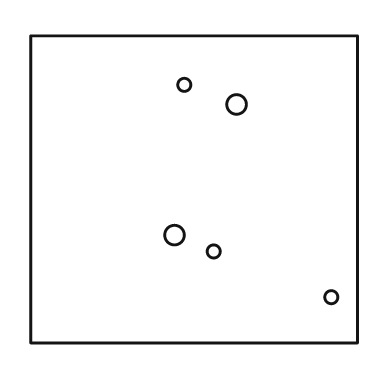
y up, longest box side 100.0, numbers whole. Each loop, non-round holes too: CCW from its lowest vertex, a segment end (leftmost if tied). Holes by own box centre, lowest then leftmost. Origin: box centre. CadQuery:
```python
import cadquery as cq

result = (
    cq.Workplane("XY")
    .moveTo(-50.0, -47.0)
    .lineTo(50.0, -47.0)
    .lineTo(50.0, 47.0)
    .lineTo(-50.0, 47.0)
    .close()
    .moveTo(42.0, -33.0)
    .circle(2.0)
    .moveTo(6.0, -19.0)
    .circle(2.0)
    .moveTo(-6.0, -14.0)
    .circle(3.0)
    .moveTo(13.0, 26.0)
    .circle(3.0)
    .moveTo(-3.0, 32.0)
    .circle(2.0)
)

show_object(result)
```